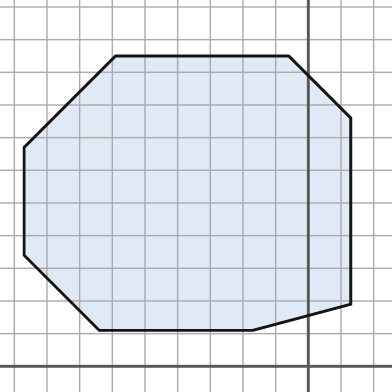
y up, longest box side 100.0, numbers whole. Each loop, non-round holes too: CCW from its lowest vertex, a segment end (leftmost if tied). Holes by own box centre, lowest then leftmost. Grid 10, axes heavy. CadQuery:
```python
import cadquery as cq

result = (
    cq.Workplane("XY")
    .moveTo(-64.0, 11.0)
    .lineTo(-17.0, 11.0)
    .lineTo(13.0, 19.0)
    .lineTo(13.0, 76.0)
    .lineTo(-6.0, 95.0)
    .lineTo(-59.0, 95.0)
    .lineTo(-87.0, 67.0)
    .lineTo(-87.0, 34.0)
    .close()
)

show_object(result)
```